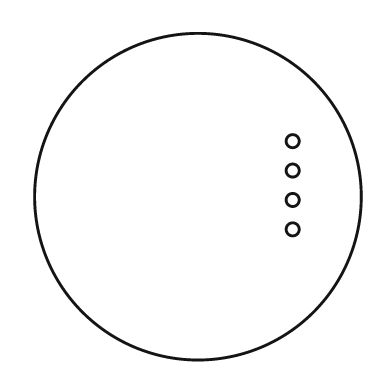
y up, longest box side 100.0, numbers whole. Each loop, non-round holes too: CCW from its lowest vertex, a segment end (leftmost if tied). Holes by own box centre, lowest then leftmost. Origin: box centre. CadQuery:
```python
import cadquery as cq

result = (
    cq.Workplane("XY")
    .moveTo(0.0, 0.0)
    .circle(50.0)
    .moveTo(29.0, -10.0)
    .circle(2.0)
    .moveTo(29.0, -1.0)
    .circle(2.0)
    .moveTo(29.0, 8.0)
    .circle(2.0)
    .moveTo(29.0, 17.0)
    .circle(2.0)
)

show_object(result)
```